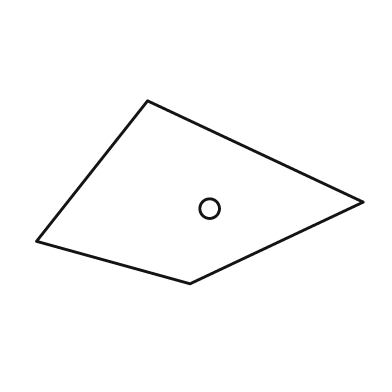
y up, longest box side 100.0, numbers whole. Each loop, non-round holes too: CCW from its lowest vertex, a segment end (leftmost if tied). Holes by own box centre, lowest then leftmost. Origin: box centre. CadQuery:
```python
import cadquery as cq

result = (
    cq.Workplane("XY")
    .moveTo(-3.0, -28.0)
    .lineTo(50.0, -3.0)
    .lineTo(-16.0, 28.0)
    .lineTo(-50.0, -15.0)
    .close()
    .moveTo(3.0, -5.0)
    .circle(3.0)
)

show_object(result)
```